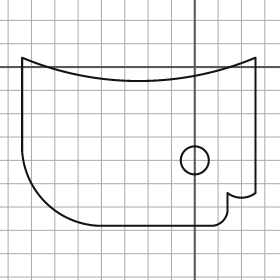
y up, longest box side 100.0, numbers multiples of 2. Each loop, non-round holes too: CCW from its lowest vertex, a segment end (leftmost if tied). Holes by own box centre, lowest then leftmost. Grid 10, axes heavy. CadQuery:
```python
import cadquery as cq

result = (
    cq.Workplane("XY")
    .moveTo(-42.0, -68.0)
    .lineTo(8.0, -68.0)
    .threePointArc((12.0, -66.0), (14.0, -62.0))
    .lineTo(14.0, -54.0)
    .threePointArc((20.0, -56.0), (26.0, -54.0))
    .lineTo(26.0, 4.0)
    .threePointArc((-24.0, -6.0), (-74.0, 4.0))
    .lineTo(-74.0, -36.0)
    .threePointArc((-64.0, -58.0), (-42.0, -68.0))
    .close()
    .moveTo(0.0, -40.0)
    .circle(6.0)
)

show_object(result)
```